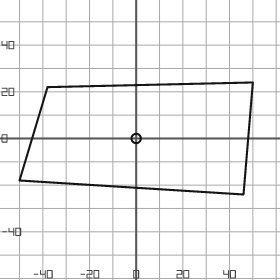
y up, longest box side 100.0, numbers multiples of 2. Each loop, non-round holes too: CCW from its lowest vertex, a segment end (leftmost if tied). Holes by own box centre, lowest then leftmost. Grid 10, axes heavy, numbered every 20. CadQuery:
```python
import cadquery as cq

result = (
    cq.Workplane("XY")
    .moveTo(46.0, -24.0)
    .lineTo(50.0, 24.0)
    .lineTo(-38.0, 22.0)
    .lineTo(-50.0, -18.0)
    .close()
    .moveTo(0.0, 0.0)
    .circle(2.0)
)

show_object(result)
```